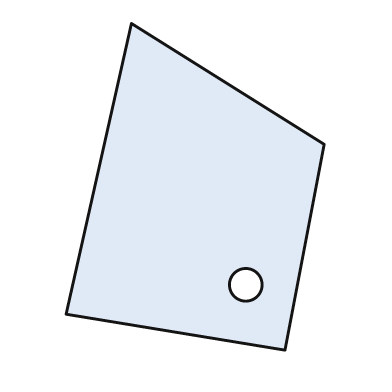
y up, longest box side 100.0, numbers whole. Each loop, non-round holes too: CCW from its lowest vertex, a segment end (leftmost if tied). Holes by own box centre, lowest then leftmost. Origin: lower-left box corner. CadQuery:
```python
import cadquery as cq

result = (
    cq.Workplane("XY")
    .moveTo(67.0, 0.0)
    .lineTo(79.0, 63.0)
    .lineTo(20.0, 100.0)
    .lineTo(0.0, 11.0)
    .close()
    .moveTo(55.0, 20.0)
    .circle(5.0)
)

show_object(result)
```